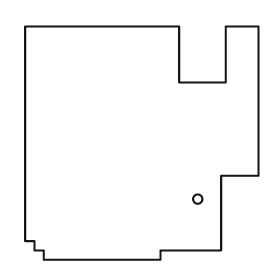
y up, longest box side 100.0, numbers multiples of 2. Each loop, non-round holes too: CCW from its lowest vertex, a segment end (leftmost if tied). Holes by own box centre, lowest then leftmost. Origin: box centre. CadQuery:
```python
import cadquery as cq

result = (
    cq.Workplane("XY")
    .moveTo(-42.0, -50.0)
    .lineTo(8.0, -50.0)
    .lineTo(8.0, -46.0)
    .lineTo(34.0, -46.0)
    .lineTo(34.0, -14.0)
    .lineTo(50.0, -14.0)
    .lineTo(50.0, 50.0)
    .lineTo(36.0, 50.0)
    .lineTo(36.0, 26.0)
    .lineTo(16.0, 26.0)
    .lineTo(16.0, 50.0)
    .lineTo(-50.0, 50.0)
    .lineTo(-50.0, -42.0)
    .lineTo(-46.0, -42.0)
    .lineTo(-46.0, -46.0)
    .lineTo(-42.0, -46.0)
    .close()
    .moveTo(24.0, -24.0)
    .circle(2.0)
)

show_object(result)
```